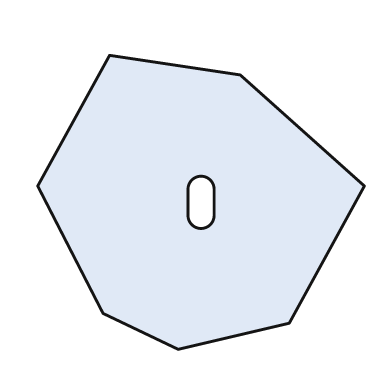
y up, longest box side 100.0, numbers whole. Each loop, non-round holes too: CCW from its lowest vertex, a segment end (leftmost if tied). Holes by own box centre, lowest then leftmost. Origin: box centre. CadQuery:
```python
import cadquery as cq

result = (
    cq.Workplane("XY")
    .moveTo(-7.0, -45.0)
    .lineTo(27.0, -37.0)
    .lineTo(50.0, 5.0)
    .lineTo(12.0, 39.0)
    .lineTo(-28.0, 45.0)
    .lineTo(-50.0, 5.0)
    .lineTo(-30.0, -34.0)
    .close()
    .moveTo(-4.0, -4.0)
    .threePointArc((0.0, -8.0), (4.0, -4.0))
    .lineTo(4.0, 4.0)
    .threePointArc((0.0, 8.0), (-4.0, 4.0))
    .close()
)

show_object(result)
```